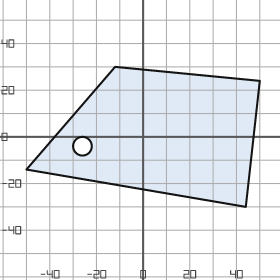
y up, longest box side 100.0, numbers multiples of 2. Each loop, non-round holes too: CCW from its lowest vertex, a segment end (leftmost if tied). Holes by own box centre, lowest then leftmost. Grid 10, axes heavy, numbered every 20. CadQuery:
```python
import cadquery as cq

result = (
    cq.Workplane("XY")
    .moveTo(44.0, -30.0)
    .lineTo(50.0, 24.0)
    .lineTo(-12.0, 30.0)
    .lineTo(-50.0, -14.0)
    .close()
    .moveTo(-26.0, -4.0)
    .circle(4.0)
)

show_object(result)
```